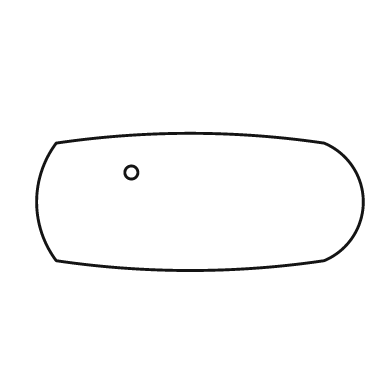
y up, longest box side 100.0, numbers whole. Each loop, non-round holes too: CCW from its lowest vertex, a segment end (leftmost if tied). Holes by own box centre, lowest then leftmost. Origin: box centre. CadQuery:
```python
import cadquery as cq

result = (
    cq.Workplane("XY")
    .moveTo(-44.0, -18.0)
    .threePointArc((-3.0, -21.0), (38.0, -18.0))
    .threePointArc((50.0, 0.0), (38.0, 18.0))
    .threePointArc((-3.0, 21.0), (-44.0, 18.0))
    .threePointArc((-50.0, 0.0), (-44.0, -18.0))
    .close()
    .moveTo(-21.0, 9.0)
    .circle(2.0)
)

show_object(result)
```